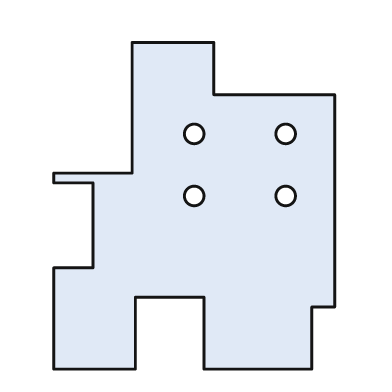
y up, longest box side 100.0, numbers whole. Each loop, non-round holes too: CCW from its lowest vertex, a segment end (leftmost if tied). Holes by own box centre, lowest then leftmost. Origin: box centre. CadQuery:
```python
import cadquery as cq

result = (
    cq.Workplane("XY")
    .moveTo(-43.0, -50.0)
    .lineTo(-18.0, -50.0)
    .lineTo(-18.0, -28.0)
    .lineTo(3.0, -28.0)
    .lineTo(3.0, -50.0)
    .lineTo(36.0, -50.0)
    .lineTo(36.0, -31.0)
    .lineTo(43.0, -31.0)
    .lineTo(43.0, 34.0)
    .lineTo(6.0, 34.0)
    .lineTo(6.0, 50.0)
    .lineTo(-19.0, 50.0)
    .lineTo(-19.0, 10.0)
    .lineTo(-43.0, 10.0)
    .lineTo(-43.0, 7.0)
    .lineTo(-31.0, 7.0)
    .lineTo(-31.0, -19.0)
    .lineTo(-43.0, -19.0)
    .close()
    .moveTo(0.0, 3.0)
    .circle(3.0)
    .moveTo(28.0, 3.0)
    .circle(3.0)
    .moveTo(0.0, 22.0)
    .circle(3.0)
    .moveTo(28.0, 22.0)
    .circle(3.0)
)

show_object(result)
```